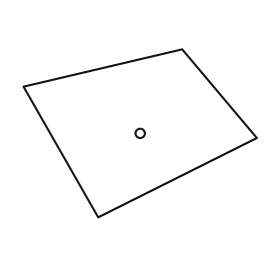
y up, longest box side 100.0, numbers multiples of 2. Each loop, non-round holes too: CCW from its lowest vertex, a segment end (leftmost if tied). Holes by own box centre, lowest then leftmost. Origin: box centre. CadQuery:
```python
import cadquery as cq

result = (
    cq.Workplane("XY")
    .moveTo(-18.0, -36.0)
    .lineTo(50.0, -2.0)
    .lineTo(18.0, 36.0)
    .lineTo(-50.0, 20.0)
    .close()
    .moveTo(0.0, 0.0)
    .circle(2.0)
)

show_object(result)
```